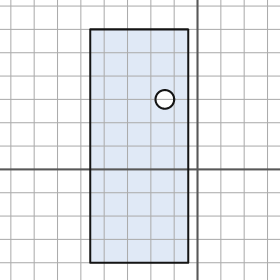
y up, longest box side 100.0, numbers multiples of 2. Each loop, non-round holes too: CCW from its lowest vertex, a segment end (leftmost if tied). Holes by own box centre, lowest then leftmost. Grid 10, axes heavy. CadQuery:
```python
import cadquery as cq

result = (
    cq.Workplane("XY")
    .moveTo(-46.0, -40.0)
    .lineTo(-4.0, -40.0)
    .lineTo(-4.0, 60.0)
    .lineTo(-46.0, 60.0)
    .close()
    .moveTo(-14.0, 30.0)
    .circle(4.0)
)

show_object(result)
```